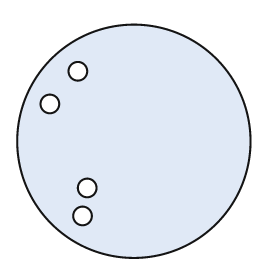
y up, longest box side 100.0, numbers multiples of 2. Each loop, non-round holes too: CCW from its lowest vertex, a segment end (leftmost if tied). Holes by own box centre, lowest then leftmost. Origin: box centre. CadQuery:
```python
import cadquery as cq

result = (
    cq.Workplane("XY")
    .moveTo(0.0, 0.0)
    .circle(50.0)
    .moveTo(-22.0, -32.0)
    .circle(4.0)
    .moveTo(-20.0, -20.0)
    .circle(4.0)
    .moveTo(-36.0, 16.0)
    .circle(4.0)
    .moveTo(-24.0, 30.0)
    .circle(4.0)
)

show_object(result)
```